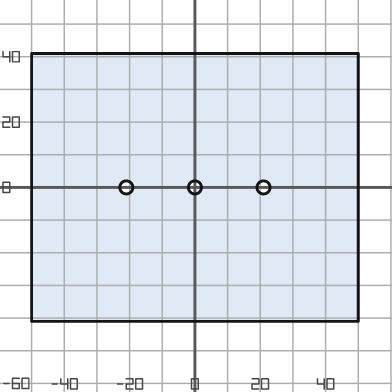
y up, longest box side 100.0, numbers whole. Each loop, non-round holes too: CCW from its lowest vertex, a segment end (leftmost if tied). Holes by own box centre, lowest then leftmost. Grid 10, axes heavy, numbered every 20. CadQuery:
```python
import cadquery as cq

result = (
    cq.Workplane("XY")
    .moveTo(-50.0, -41.0)
    .lineTo(50.0, -41.0)
    .lineTo(50.0, 41.0)
    .lineTo(-50.0, 41.0)
    .close()
    .moveTo(-21.0, 0.0)
    .circle(2.0)
    .moveTo(0.0, 0.0)
    .circle(2.0)
    .moveTo(21.0, 0.0)
    .circle(2.0)
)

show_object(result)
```